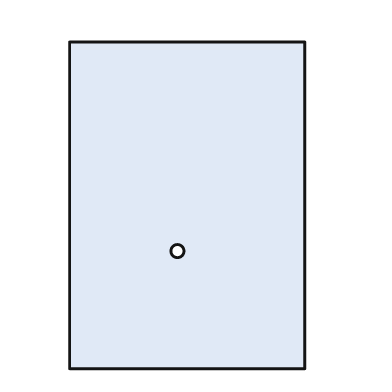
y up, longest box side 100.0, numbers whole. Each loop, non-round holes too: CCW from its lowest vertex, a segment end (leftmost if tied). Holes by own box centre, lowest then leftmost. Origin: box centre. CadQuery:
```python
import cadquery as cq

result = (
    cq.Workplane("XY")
    .moveTo(-36.0, -50.0)
    .lineTo(36.0, -50.0)
    .lineTo(36.0, 50.0)
    .lineTo(-36.0, 50.0)
    .close()
    .moveTo(-3.0, -14.0)
    .circle(2.0)
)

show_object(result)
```